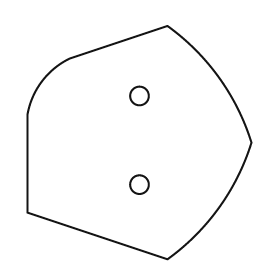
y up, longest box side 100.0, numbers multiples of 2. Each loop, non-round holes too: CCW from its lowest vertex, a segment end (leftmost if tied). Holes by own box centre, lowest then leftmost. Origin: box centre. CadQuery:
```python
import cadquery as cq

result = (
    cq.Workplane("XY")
    .moveTo(12.0, -50.0)
    .threePointArc((34.0, -28.0), (48.0, 0.0))
    .threePointArc((34.0, 28.0), (12.0, 50.0))
    .lineTo(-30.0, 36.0)
    .threePointArc((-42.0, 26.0), (-48.0, 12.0))
    .lineTo(-48.0, -30.0)
    .close()
    .moveTo(0.0, -18.0)
    .circle(4.0)
    .moveTo(0.0, 20.0)
    .circle(4.0)
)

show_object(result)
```